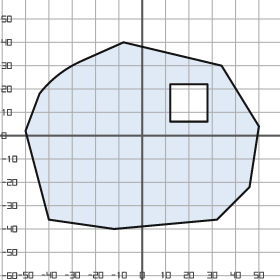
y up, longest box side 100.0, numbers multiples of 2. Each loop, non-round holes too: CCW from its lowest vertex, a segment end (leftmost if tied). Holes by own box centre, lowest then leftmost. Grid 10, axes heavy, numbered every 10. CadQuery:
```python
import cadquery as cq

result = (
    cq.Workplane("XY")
    .moveTo(-12.0, -40.0)
    .lineTo(32.0, -36.0)
    .lineTo(46.0, -22.0)
    .lineTo(50.0, 4.0)
    .lineTo(34.0, 30.0)
    .lineTo(-8.0, 40.0)
    .lineTo(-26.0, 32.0)
    .threePointArc((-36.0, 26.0), (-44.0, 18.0))
    .lineTo(-50.0, 2.0)
    .lineTo(-40.0, -36.0)
    .close()
    .moveTo(12.0, 6.0)
    .lineTo(28.0, 6.0)
    .lineTo(28.0, 22.0)
    .lineTo(12.0, 22.0)
    .close()
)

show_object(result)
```